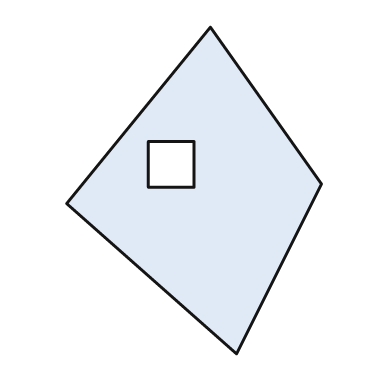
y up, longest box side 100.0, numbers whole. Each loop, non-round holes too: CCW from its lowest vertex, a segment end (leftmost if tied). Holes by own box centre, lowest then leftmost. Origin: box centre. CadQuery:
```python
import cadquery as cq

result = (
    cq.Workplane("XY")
    .moveTo(13.0, -50.0)
    .lineTo(39.0, 2.0)
    .lineTo(5.0, 50.0)
    .lineTo(-39.0, -4.0)
    .close()
    .moveTo(-14.0, 1.0)
    .lineTo(0.0, 1.0)
    .lineTo(0.0, 15.0)
    .lineTo(-14.0, 15.0)
    .close()
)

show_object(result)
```